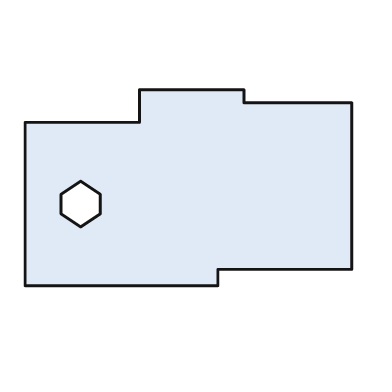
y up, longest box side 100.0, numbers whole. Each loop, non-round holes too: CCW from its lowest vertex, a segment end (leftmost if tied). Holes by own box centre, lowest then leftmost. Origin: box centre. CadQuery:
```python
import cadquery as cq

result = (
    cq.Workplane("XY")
    .moveTo(-50.0, -30.0)
    .lineTo(9.0, -30.0)
    .lineTo(9.0, -25.0)
    .lineTo(50.0, -25.0)
    .lineTo(50.0, 26.0)
    .lineTo(17.0, 26.0)
    .lineTo(17.0, 30.0)
    .lineTo(-15.0, 30.0)
    .lineTo(-15.0, 20.0)
    .lineTo(-50.0, 20.0)
    .close()
    .moveTo(-33.0, -12.0)
    .lineTo(-27.0, -8.0)
    .lineTo(-27.0, -2.0)
    .lineTo(-33.0, 2.0)
    .lineTo(-39.0, -2.0)
    .lineTo(-39.0, -8.0)
    .close()
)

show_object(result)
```